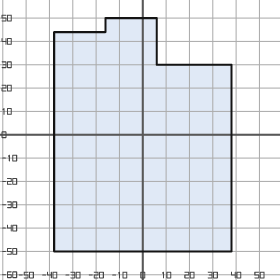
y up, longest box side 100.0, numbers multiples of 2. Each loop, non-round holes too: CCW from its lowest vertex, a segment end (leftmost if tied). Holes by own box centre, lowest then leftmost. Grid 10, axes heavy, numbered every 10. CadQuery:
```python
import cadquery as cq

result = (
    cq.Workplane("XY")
    .moveTo(-38.0, -50.0)
    .lineTo(38.0, -50.0)
    .lineTo(38.0, 30.0)
    .lineTo(6.0, 30.0)
    .lineTo(6.0, 50.0)
    .lineTo(-16.0, 50.0)
    .lineTo(-16.0, 44.0)
    .lineTo(-38.0, 44.0)
    .close()
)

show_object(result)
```